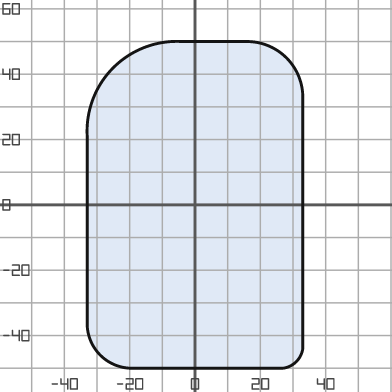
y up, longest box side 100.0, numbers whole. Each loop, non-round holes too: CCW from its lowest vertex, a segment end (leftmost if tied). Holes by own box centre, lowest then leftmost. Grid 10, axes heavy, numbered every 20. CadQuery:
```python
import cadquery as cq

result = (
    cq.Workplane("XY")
    .moveTo(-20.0, -50.0)
    .lineTo(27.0, -50.0)
    .threePointArc((31.0, -48.0), (33.0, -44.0))
    .lineTo(33.0, 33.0)
    .threePointArc((28.0, 45.0), (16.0, 50.0))
    .lineTo(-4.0, 50.0)
    .threePointArc((-25.0, 42.0), (-33.0, 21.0))
    .lineTo(-33.0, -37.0)
    .threePointArc((-29.0, -46.0), (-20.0, -50.0))
    .close()
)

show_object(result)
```